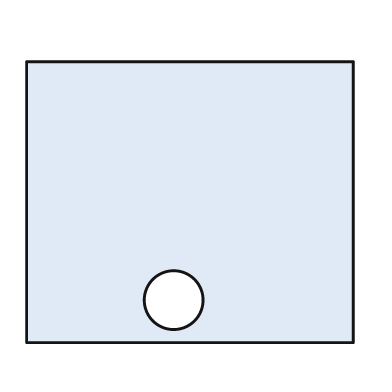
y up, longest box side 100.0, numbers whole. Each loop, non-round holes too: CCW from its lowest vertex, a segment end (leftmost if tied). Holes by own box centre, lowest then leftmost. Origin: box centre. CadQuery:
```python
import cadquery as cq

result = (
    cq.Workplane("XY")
    .moveTo(-50.0, -43.0)
    .lineTo(50.0, -43.0)
    .lineTo(50.0, 43.0)
    .lineTo(-50.0, 43.0)
    .close()
    .moveTo(-5.0, -30.0)
    .circle(9.0)
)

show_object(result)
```